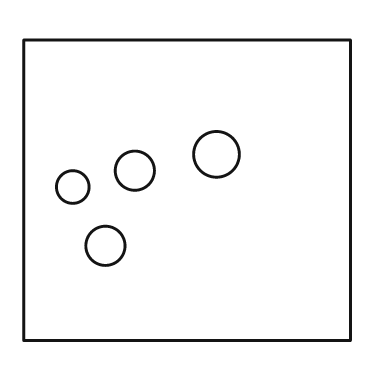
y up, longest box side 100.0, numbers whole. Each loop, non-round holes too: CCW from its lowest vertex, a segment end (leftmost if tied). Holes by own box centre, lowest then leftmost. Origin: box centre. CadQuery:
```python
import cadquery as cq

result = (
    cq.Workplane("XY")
    .moveTo(-50.0, -46.0)
    .lineTo(50.0, -46.0)
    .lineTo(50.0, 46.0)
    .lineTo(-50.0, 46.0)
    .close()
    .moveTo(-25.0, -17.0)
    .circle(6.0)
    .moveTo(-35.0, 1.0)
    .circle(5.0)
    .moveTo(-16.0, 6.0)
    .circle(6.0)
    .moveTo(9.0, 11.0)
    .circle(7.0)
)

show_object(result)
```